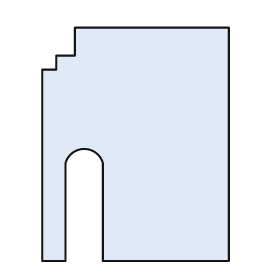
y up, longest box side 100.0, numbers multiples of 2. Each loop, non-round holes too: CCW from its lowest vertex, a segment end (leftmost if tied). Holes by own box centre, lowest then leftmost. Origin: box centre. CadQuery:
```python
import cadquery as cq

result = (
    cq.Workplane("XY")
    .moveTo(-40.0, -50.0)
    .lineTo(-30.0, -50.0)
    .lineTo(-30.0, -8.0)
    .threePointArc((-22.0, -2.0), (-14.0, -8.0))
    .lineTo(-14.0, -50.0)
    .lineTo(40.0, -50.0)
    .lineTo(40.0, 50.0)
    .lineTo(-26.0, 50.0)
    .lineTo(-26.0, 38.0)
    .lineTo(-34.0, 38.0)
    .lineTo(-34.0, 32.0)
    .lineTo(-40.0, 32.0)
    .close()
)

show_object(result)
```